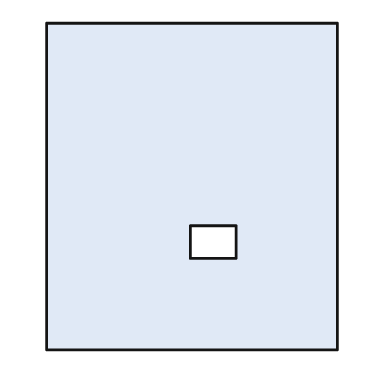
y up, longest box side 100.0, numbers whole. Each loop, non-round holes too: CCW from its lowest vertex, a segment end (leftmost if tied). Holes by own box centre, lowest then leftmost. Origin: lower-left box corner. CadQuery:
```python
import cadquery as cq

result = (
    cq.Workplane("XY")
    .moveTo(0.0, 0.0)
    .lineTo(89.0, 0.0)
    .lineTo(89.0, 100.0)
    .lineTo(0.0, 100.0)
    .close()
    .moveTo(44.0, 28.0)
    .lineTo(58.0, 28.0)
    .lineTo(58.0, 38.0)
    .lineTo(44.0, 38.0)
    .close()
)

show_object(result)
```